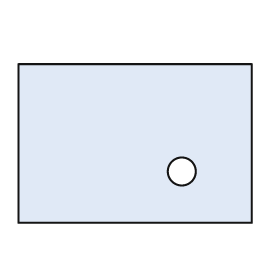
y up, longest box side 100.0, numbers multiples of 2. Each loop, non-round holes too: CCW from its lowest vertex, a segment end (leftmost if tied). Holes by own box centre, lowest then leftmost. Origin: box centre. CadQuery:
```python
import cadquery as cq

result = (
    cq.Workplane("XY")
    .moveTo(-50.0, -34.0)
    .lineTo(50.0, -34.0)
    .lineTo(50.0, 34.0)
    .lineTo(-50.0, 34.0)
    .close()
    .moveTo(20.0, -12.0)
    .circle(6.0)
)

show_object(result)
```